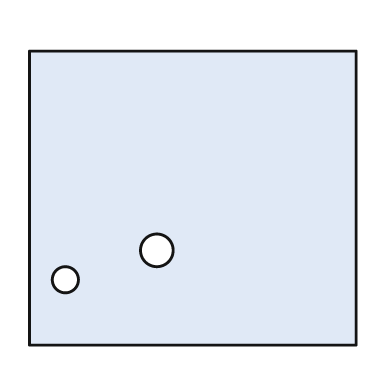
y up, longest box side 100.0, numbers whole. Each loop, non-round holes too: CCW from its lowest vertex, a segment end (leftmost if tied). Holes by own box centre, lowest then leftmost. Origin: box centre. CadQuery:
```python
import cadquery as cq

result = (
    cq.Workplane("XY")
    .moveTo(-50.0, -45.0)
    .lineTo(50.0, -45.0)
    .lineTo(50.0, 45.0)
    .lineTo(-50.0, 45.0)
    .close()
    .moveTo(-39.0, -25.0)
    .circle(4.0)
    .moveTo(-11.0, -16.0)
    .circle(5.0)
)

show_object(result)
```